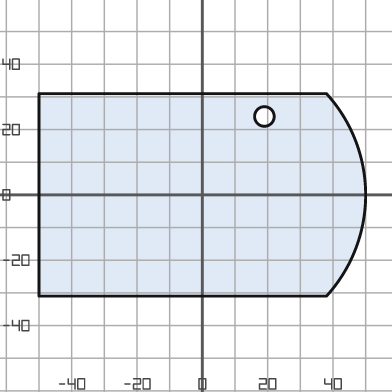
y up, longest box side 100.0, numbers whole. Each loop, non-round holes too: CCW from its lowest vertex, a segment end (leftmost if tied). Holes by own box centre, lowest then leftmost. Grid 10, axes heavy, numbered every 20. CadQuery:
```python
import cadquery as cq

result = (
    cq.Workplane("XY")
    .moveTo(-50.0, -31.0)
    .lineTo(38.0, -31.0)
    .threePointArc((50.0, 0.0), (38.0, 31.0))
    .lineTo(-50.0, 31.0)
    .close()
    .moveTo(19.0, 24.0)
    .circle(3.0)
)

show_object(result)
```